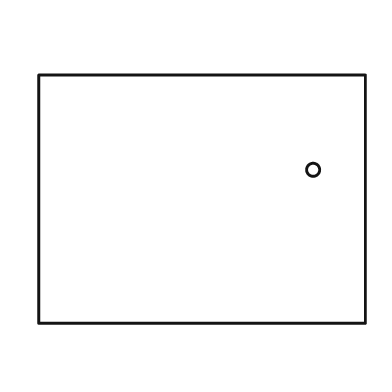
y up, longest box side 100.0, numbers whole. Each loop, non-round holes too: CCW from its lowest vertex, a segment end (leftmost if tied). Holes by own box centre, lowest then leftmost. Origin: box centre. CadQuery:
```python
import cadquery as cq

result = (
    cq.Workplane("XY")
    .moveTo(-50.0, -38.0)
    .lineTo(50.0, -38.0)
    .lineTo(50.0, 38.0)
    .lineTo(-50.0, 38.0)
    .close()
    .moveTo(34.0, 9.0)
    .circle(2.0)
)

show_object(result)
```